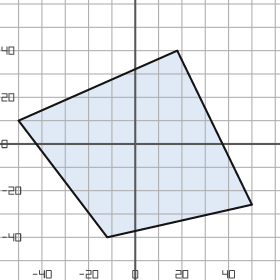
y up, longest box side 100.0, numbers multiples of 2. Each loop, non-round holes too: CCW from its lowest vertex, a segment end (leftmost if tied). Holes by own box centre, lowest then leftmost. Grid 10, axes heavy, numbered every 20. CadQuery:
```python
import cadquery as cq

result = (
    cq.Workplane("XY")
    .moveTo(-12.0, -40.0)
    .lineTo(50.0, -26.0)
    .lineTo(18.0, 40.0)
    .lineTo(-50.0, 10.0)
    .close()
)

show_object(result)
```